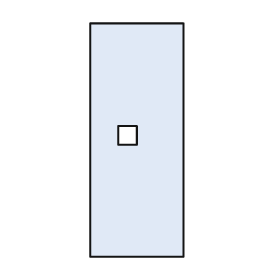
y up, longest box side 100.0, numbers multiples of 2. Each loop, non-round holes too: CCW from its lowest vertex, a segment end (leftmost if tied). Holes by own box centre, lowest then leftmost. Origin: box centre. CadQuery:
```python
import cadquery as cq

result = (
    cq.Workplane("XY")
    .moveTo(-20.0, -50.0)
    .lineTo(20.0, -50.0)
    .lineTo(20.0, 50.0)
    .lineTo(-20.0, 50.0)
    .close()
    .moveTo(-8.0, -2.0)
    .lineTo(0.0, -2.0)
    .lineTo(0.0, 6.0)
    .lineTo(-8.0, 6.0)
    .close()
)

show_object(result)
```